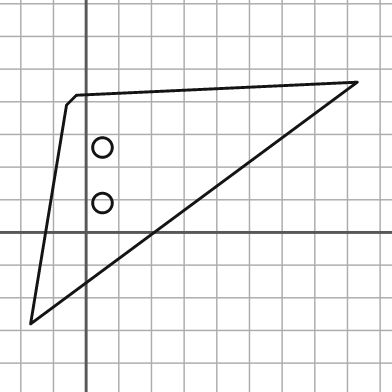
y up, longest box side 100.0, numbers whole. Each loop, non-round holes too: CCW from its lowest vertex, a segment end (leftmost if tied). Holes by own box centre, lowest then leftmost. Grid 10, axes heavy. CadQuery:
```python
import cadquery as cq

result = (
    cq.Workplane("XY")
    .moveTo(-17.0, -28.0)
    .lineTo(83.0, 46.0)
    .lineTo(-3.0, 42.0)
    .lineTo(-6.0, 39.0)
    .close()
    .moveTo(5.0, 9.0)
    .circle(3.0)
    .moveTo(5.0, 26.0)
    .circle(3.0)
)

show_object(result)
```